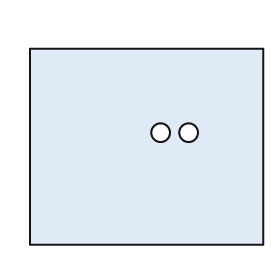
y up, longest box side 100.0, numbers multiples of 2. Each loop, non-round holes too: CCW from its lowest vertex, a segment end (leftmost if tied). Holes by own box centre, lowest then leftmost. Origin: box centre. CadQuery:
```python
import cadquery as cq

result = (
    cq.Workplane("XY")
    .moveTo(-50.0, -42.0)
    .lineTo(50.0, -42.0)
    .lineTo(50.0, 42.0)
    .lineTo(-50.0, 42.0)
    .close()
    .moveTo(6.0, 6.0)
    .circle(4.0)
    .moveTo(18.0, 6.0)
    .circle(4.0)
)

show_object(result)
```